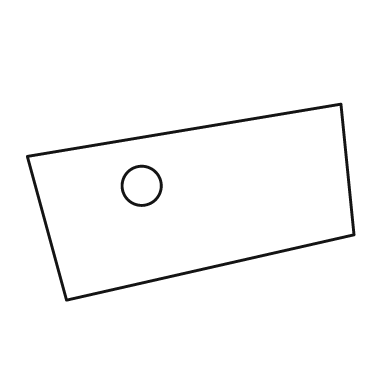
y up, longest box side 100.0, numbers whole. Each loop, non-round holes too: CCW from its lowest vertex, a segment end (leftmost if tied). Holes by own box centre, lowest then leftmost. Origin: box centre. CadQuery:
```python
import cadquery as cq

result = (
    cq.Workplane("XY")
    .moveTo(-38.0, -30.0)
    .lineTo(50.0, -10.0)
    .lineTo(46.0, 30.0)
    .lineTo(-50.0, 14.0)
    .close()
    .moveTo(-15.0, 5.0)
    .circle(6.0)
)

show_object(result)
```